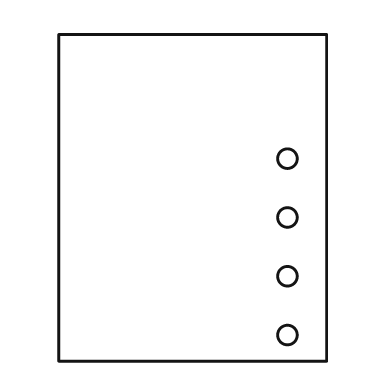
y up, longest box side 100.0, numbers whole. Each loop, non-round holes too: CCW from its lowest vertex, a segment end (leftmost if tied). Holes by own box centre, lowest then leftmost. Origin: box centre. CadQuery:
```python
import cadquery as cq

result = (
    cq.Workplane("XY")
    .moveTo(-41.0, -50.0)
    .lineTo(41.0, -50.0)
    .lineTo(41.0, 50.0)
    .lineTo(-41.0, 50.0)
    .close()
    .moveTo(29.0, -42.0)
    .circle(3.0)
    .moveTo(29.0, -24.0)
    .circle(3.0)
    .moveTo(29.0, -6.0)
    .circle(3.0)
    .moveTo(29.0, 12.0)
    .circle(3.0)
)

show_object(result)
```